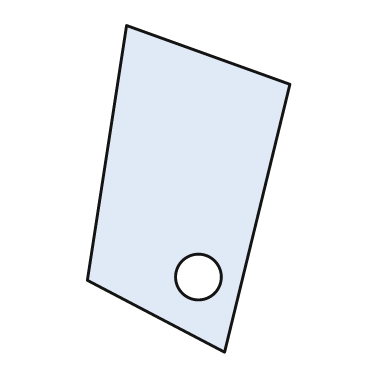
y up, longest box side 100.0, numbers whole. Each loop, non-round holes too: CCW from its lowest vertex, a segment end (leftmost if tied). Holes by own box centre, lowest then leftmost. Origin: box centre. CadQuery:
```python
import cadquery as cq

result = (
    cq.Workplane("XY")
    .moveTo(11.0, -50.0)
    .lineTo(31.0, 32.0)
    .lineTo(-19.0, 50.0)
    .lineTo(-31.0, -28.0)
    .close()
    .moveTo(3.0, -27.0)
    .circle(7.0)
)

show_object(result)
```